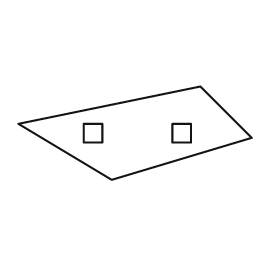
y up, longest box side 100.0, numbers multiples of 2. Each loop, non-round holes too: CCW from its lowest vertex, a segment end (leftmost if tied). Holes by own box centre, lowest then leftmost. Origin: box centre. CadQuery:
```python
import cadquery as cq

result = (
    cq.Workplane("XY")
    .moveTo(-10.0, -20.0)
    .lineTo(50.0, -2.0)
    .lineTo(28.0, 20.0)
    .lineTo(-50.0, 4.0)
    .close()
    .moveTo(-22.0, -4.0)
    .lineTo(-14.0, -4.0)
    .lineTo(-14.0, 4.0)
    .lineTo(-22.0, 4.0)
    .close()
    .moveTo(16.0, -4.0)
    .lineTo(24.0, -4.0)
    .lineTo(24.0, 4.0)
    .lineTo(16.0, 4.0)
    .close()
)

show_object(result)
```